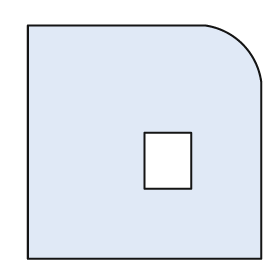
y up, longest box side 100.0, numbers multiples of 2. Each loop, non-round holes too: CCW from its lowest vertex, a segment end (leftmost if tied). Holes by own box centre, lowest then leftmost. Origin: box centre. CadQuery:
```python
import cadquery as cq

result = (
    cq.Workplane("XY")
    .moveTo(-50.0, -50.0)
    .lineTo(50.0, -50.0)
    .lineTo(50.0, 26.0)
    .threePointArc((42.0, 42.0), (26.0, 50.0))
    .lineTo(-50.0, 50.0)
    .close()
    .moveTo(0.0, -20.0)
    .lineTo(20.0, -20.0)
    .lineTo(20.0, 4.0)
    .lineTo(0.0, 4.0)
    .close()
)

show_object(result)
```